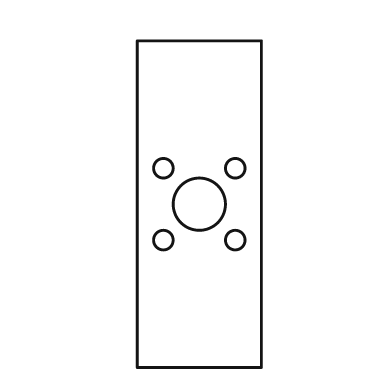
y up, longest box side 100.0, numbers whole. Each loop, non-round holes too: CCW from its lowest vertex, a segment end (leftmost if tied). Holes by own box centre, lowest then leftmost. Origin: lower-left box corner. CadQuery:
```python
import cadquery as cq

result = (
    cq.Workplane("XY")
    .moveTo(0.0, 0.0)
    .lineTo(38.0, 0.0)
    .lineTo(38.0, 100.0)
    .lineTo(0.0, 100.0)
    .close()
    .moveTo(8.0, 39.0)
    .circle(3.0)
    .moveTo(30.0, 39.0)
    .circle(3.0)
    .moveTo(19.0, 50.0)
    .circle(8.0)
    .moveTo(8.0, 61.0)
    .circle(3.0)
    .moveTo(30.0, 61.0)
    .circle(3.0)
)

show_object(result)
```